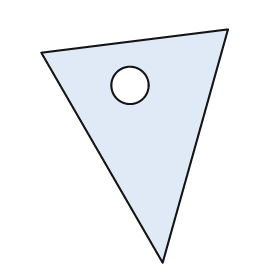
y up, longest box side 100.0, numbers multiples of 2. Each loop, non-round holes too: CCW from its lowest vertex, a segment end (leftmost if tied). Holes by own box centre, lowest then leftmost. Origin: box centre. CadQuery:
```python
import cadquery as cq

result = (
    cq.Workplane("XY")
    .moveTo(12.0, -50.0)
    .lineTo(40.0, 50.0)
    .lineTo(-40.0, 40.0)
    .close()
    .moveTo(-2.0, 26.0)
    .circle(8.0)
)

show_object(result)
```